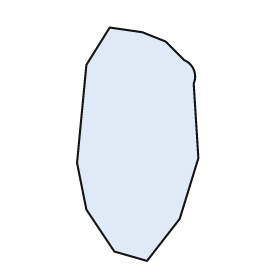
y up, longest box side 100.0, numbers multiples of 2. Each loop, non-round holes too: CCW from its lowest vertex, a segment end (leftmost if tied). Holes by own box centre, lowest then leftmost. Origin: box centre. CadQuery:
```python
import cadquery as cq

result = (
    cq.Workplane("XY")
    .moveTo(4.0, -50.0)
    .lineTo(18.0, -32.0)
    .lineTo(26.0, -6.0)
    .lineTo(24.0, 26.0)
    .threePointArc((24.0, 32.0), (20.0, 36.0))
    .lineTo(12.0, 44.0)
    .lineTo(2.0, 48.0)
    .lineTo(-12.0, 50.0)
    .lineTo(-22.0, 34.0)
    .lineTo(-26.0, -8.0)
    .lineTo(-22.0, -28.0)
    .lineTo(-10.0, -46.0)
    .close()
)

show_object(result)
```